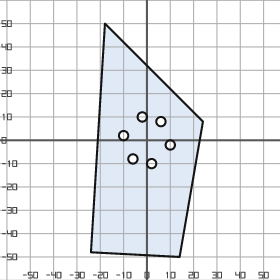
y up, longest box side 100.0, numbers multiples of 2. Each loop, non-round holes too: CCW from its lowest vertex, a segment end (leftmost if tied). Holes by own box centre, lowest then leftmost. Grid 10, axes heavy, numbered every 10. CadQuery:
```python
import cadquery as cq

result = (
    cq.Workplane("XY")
    .moveTo(14.0, -50.0)
    .lineTo(24.0, 8.0)
    .lineTo(-18.0, 50.0)
    .lineTo(-24.0, -48.0)
    .close()
    .moveTo(2.0, -10.0)
    .circle(2.0)
    .moveTo(-6.0, -8.0)
    .circle(2.0)
    .moveTo(10.0, -2.0)
    .circle(2.0)
    .moveTo(-10.0, 2.0)
    .circle(2.0)
    .moveTo(6.0, 8.0)
    .circle(2.0)
    .moveTo(-2.0, 10.0)
    .circle(2.0)
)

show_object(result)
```